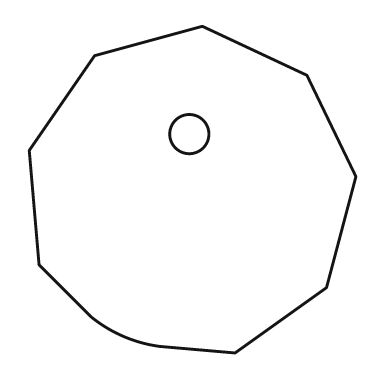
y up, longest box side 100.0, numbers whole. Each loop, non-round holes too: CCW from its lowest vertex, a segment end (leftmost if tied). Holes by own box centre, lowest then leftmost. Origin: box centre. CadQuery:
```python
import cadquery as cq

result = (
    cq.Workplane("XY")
    .moveTo(13.0, -50.0)
    .lineTo(41.0, -30.0)
    .lineTo(50.0, 4.0)
    .lineTo(35.0, 35.0)
    .lineTo(3.0, 50.0)
    .lineTo(-30.0, 41.0)
    .lineTo(-50.0, 12.0)
    .lineTo(-47.0, -23.0)
    .lineTo(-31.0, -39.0)
    .threePointArc((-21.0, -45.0), (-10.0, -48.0))
    .close()
    .moveTo(-1.0, 17.0)
    .circle(6.0)
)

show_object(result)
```